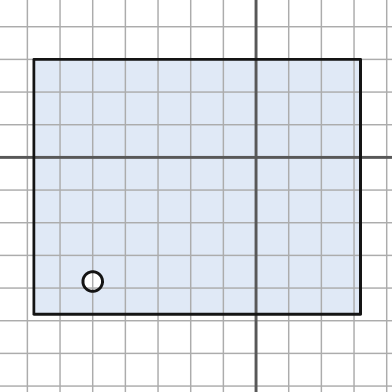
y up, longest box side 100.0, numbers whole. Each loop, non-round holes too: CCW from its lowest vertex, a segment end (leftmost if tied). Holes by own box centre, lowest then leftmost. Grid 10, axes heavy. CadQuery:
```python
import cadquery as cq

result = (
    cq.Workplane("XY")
    .moveTo(-68.0, -48.0)
    .lineTo(32.0, -48.0)
    .lineTo(32.0, 30.0)
    .lineTo(-68.0, 30.0)
    .close()
    .moveTo(-50.0, -38.0)
    .circle(3.0)
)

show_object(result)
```